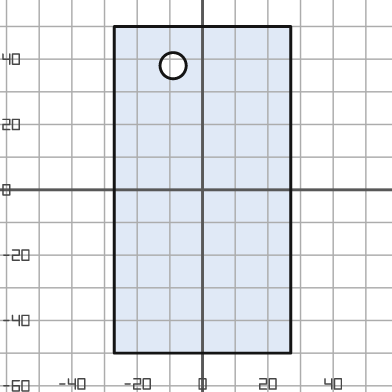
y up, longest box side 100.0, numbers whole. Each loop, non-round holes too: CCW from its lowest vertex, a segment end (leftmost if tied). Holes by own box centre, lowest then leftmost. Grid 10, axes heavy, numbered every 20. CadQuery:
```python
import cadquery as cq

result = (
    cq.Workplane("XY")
    .moveTo(-27.0, -50.0)
    .lineTo(27.0, -50.0)
    .lineTo(27.0, 50.0)
    .lineTo(-27.0, 50.0)
    .close()
    .moveTo(-9.0, 38.0)
    .circle(4.0)
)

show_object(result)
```